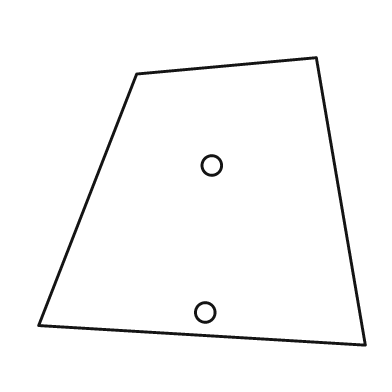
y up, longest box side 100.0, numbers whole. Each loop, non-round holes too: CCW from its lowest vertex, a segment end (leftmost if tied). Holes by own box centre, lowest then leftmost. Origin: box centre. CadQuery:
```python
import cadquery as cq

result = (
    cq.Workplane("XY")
    .moveTo(50.0, -44.0)
    .lineTo(35.0, 44.0)
    .lineTo(-20.0, 39.0)
    .lineTo(-50.0, -38.0)
    .close()
    .moveTo(1.0, -34.0)
    .circle(3.0)
    .moveTo(3.0, 11.0)
    .circle(3.0)
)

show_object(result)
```